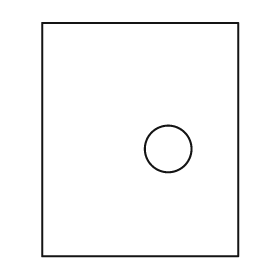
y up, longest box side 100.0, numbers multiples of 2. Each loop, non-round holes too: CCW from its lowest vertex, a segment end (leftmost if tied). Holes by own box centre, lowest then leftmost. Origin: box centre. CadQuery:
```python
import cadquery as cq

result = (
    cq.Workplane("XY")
    .moveTo(-42.0, -50.0)
    .lineTo(42.0, -50.0)
    .lineTo(42.0, 50.0)
    .lineTo(-42.0, 50.0)
    .close()
    .moveTo(12.0, -4.0)
    .circle(10.0)
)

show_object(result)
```